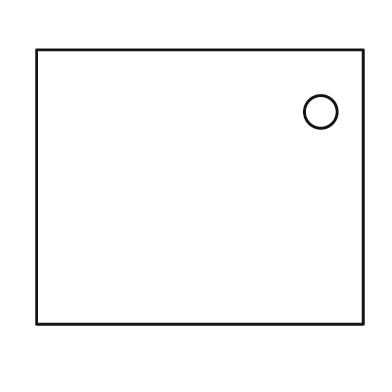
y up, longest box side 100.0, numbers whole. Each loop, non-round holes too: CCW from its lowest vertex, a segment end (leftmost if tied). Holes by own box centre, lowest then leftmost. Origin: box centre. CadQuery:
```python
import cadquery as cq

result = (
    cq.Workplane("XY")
    .moveTo(-50.0, -42.0)
    .lineTo(50.0, -42.0)
    .lineTo(50.0, 42.0)
    .lineTo(-50.0, 42.0)
    .close()
    .moveTo(37.0, 23.0)
    .circle(5.0)
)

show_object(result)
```